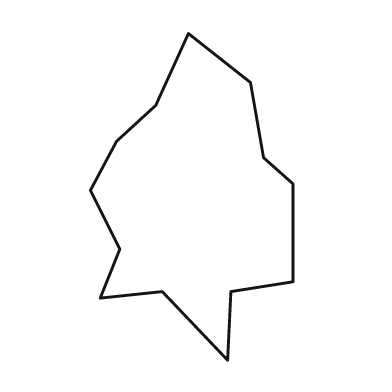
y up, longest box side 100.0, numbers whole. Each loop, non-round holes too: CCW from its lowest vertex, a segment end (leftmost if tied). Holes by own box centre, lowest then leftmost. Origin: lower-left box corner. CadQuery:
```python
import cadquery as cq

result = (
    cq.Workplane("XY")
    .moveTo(42.0, 0.0)
    .lineTo(43.0, 21.0)
    .lineTo(62.0, 24.0)
    .lineTo(62.0, 54.0)
    .lineTo(53.0, 62.0)
    .lineTo(49.0, 85.0)
    .lineTo(30.0, 100.0)
    .lineTo(20.0, 78.0)
    .lineTo(8.0, 67.0)
    .lineTo(0.0, 52.0)
    .lineTo(9.0, 34.0)
    .lineTo(3.0, 19.0)
    .lineTo(22.0, 21.0)
    .close()
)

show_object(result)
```